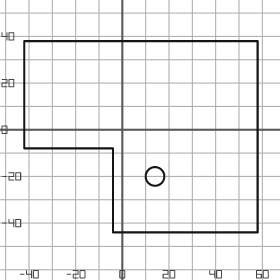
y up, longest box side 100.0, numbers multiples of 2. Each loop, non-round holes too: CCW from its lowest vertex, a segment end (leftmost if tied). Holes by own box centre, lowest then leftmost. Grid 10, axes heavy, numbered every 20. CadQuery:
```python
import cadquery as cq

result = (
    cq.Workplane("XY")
    .moveTo(-4.0, -44.0)
    .lineTo(58.0, -44.0)
    .lineTo(58.0, 38.0)
    .lineTo(-42.0, 38.0)
    .lineTo(-42.0, -8.0)
    .lineTo(-4.0, -8.0)
    .close()
    .moveTo(14.0, -20.0)
    .circle(4.0)
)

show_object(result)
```